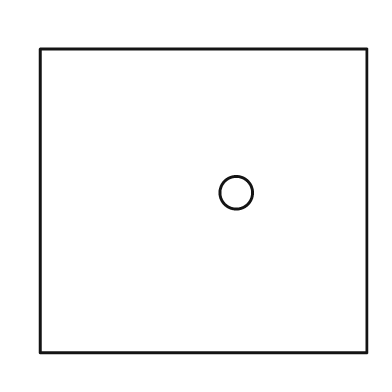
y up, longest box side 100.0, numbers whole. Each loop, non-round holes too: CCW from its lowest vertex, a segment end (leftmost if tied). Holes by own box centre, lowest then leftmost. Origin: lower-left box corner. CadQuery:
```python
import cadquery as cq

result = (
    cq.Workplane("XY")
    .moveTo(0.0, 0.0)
    .lineTo(100.0, 0.0)
    .lineTo(100.0, 93.0)
    .lineTo(0.0, 93.0)
    .close()
    .moveTo(60.0, 49.0)
    .circle(5.0)
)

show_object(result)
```